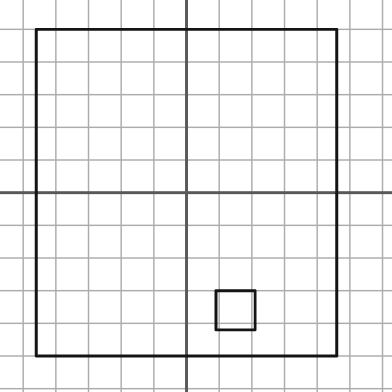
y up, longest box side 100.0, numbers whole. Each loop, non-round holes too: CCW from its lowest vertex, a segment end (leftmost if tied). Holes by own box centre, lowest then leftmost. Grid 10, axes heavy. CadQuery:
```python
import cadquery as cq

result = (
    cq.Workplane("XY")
    .moveTo(-46.0, -50.0)
    .lineTo(46.0, -50.0)
    .lineTo(46.0, 50.0)
    .lineTo(-46.0, 50.0)
    .close()
    .moveTo(9.0, -42.0)
    .lineTo(21.0, -42.0)
    .lineTo(21.0, -30.0)
    .lineTo(9.0, -30.0)
    .close()
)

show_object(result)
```